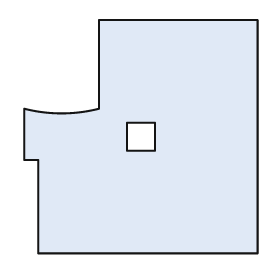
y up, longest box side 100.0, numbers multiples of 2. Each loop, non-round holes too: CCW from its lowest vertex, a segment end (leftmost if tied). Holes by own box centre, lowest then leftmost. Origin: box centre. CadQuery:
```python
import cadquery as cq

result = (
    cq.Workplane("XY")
    .moveTo(-44.0, -50.0)
    .lineTo(50.0, -50.0)
    .lineTo(50.0, 50.0)
    .lineTo(-18.0, 50.0)
    .lineTo(-18.0, 12.0)
    .threePointArc((-34.0, 10.0), (-50.0, 12.0))
    .lineTo(-50.0, -10.0)
    .lineTo(-44.0, -10.0)
    .close()
    .moveTo(-6.0, -6.0)
    .lineTo(6.0, -6.0)
    .lineTo(6.0, 6.0)
    .lineTo(-6.0, 6.0)
    .close()
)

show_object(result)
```